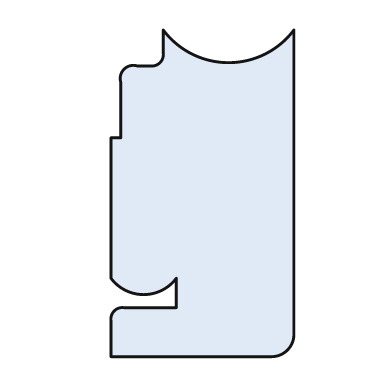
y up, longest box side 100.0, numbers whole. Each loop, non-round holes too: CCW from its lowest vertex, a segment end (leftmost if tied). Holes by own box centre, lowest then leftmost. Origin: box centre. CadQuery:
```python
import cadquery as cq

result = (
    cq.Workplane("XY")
    .moveTo(-28.0, -50.0)
    .lineTo(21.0, -50.0)
    .threePointArc((26.0, -48.0), (28.0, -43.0))
    .lineTo(28.0, 50.0)
    .threePointArc((8.0, 40.0), (-12.0, 50.0))
    .lineTo(-12.0, 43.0)
    .threePointArc((-13.0, 40.0), (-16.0, 39.0))
    .lineTo(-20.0, 39.0)
    .threePointArc((-24.0, 38.0), (-25.0, 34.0))
    .lineTo(-25.0, 17.0)
    .lineTo(-28.0, 17.0)
    .lineTo(-28.0, -26.0)
    .threePointArc((-18.0, -31.0), (-8.0, -26.0))
    .lineTo(-8.0, -35.0)
    .lineTo(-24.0, -35.0)
    .threePointArc((-27.0, -36.0), (-28.0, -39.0))
    .close()
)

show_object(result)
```